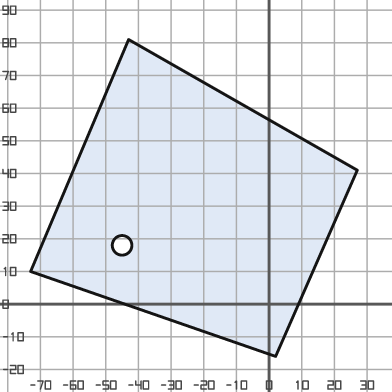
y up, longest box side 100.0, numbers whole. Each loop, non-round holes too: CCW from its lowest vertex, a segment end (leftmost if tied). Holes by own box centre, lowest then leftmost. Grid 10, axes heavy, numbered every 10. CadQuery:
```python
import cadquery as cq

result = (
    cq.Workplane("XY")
    .moveTo(2.0, -16.0)
    .lineTo(27.0, 41.0)
    .lineTo(-43.0, 81.0)
    .lineTo(-73.0, 10.0)
    .close()
    .moveTo(-45.0, 18.0)
    .circle(3.0)
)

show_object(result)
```